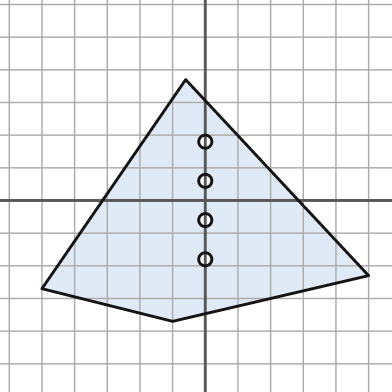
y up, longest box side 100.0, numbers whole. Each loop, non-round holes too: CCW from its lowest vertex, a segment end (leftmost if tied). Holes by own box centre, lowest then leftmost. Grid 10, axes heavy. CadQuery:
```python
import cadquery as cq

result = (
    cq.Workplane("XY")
    .moveTo(-10.0, -37.0)
    .lineTo(50.0, -23.0)
    .lineTo(-6.0, 37.0)
    .lineTo(-50.0, -27.0)
    .close()
    .moveTo(0.0, -18.0)
    .circle(2.0)
    .moveTo(0.0, -6.0)
    .circle(2.0)
    .moveTo(0.0, 6.0)
    .circle(2.0)
    .moveTo(0.0, 18.0)
    .circle(2.0)
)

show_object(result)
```